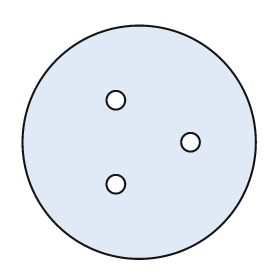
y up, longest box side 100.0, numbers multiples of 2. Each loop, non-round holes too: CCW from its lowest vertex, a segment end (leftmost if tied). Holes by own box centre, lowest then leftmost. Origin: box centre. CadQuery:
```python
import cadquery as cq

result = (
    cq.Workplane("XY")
    .moveTo(0.0, 0.0)
    .circle(50.0)
    .moveTo(-10.0, -18.0)
    .circle(4.0)
    .moveTo(22.0, 0.0)
    .circle(4.0)
    .moveTo(-10.0, 18.0)
    .circle(4.0)
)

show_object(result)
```